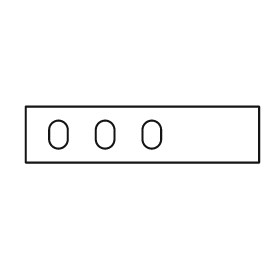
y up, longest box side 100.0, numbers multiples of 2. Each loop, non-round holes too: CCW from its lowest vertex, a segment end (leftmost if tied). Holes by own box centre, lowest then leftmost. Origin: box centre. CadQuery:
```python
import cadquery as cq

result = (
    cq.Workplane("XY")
    .moveTo(-50.0, -12.0)
    .lineTo(50.0, -12.0)
    .lineTo(50.0, 12.0)
    .lineTo(-50.0, 12.0)
    .close()
    .moveTo(-40.0, -2.0)
    .threePointArc((-36.0, -6.0), (-32.0, -2.0))
    .lineTo(-32.0, 2.0)
    .threePointArc((-36.0, 6.0), (-40.0, 2.0))
    .close()
    .moveTo(-20.0, -2.0)
    .threePointArc((-16.0, -6.0), (-12.0, -2.0))
    .lineTo(-12.0, 2.0)
    .threePointArc((-16.0, 6.0), (-20.0, 2.0))
    .close()
    .moveTo(0.0, -2.0)
    .threePointArc((4.0, -6.0), (8.0, -2.0))
    .lineTo(8.0, 2.0)
    .threePointArc((4.0, 6.0), (0.0, 2.0))
    .close()
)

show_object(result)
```